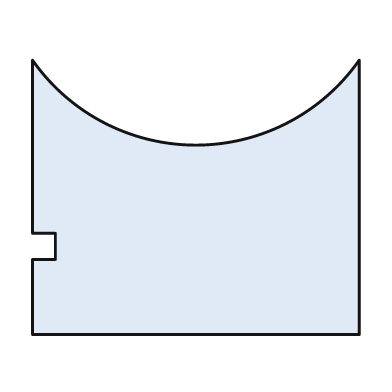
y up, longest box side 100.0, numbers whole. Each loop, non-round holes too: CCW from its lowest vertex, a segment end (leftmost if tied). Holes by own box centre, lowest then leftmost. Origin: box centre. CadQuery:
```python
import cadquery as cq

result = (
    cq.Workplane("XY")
    .moveTo(-50.0, -42.0)
    .lineTo(50.0, -42.0)
    .lineTo(50.0, 42.0)
    .threePointArc((0.0, 16.0), (-50.0, 42.0))
    .lineTo(-50.0, -11.0)
    .lineTo(-43.0, -11.0)
    .lineTo(-43.0, -19.0)
    .lineTo(-50.0, -19.0)
    .close()
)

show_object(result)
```